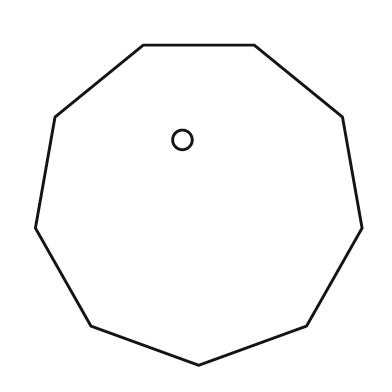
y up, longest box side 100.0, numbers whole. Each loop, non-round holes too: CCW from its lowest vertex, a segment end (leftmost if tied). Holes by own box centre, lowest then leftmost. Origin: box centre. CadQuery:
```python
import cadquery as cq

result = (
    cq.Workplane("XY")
    .moveTo(0.0, -49.0)
    .lineTo(33.0, -37.0)
    .lineTo(50.0, -7.0)
    .lineTo(44.0, 27.0)
    .lineTo(17.0, 49.0)
    .lineTo(-17.0, 49.0)
    .lineTo(-44.0, 27.0)
    .lineTo(-50.0, -7.0)
    .lineTo(-33.0, -37.0)
    .close()
    .moveTo(-5.0, 20.0)
    .circle(3.0)
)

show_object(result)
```